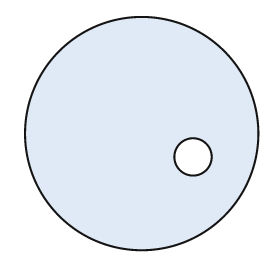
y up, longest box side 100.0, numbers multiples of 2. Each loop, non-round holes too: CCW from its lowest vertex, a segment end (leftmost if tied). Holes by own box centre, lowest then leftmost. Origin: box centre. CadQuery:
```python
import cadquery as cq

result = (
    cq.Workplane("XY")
    .moveTo(0.0, 0.0)
    .circle(50.0)
    .moveTo(22.0, -10.0)
    .circle(8.0)
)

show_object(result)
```